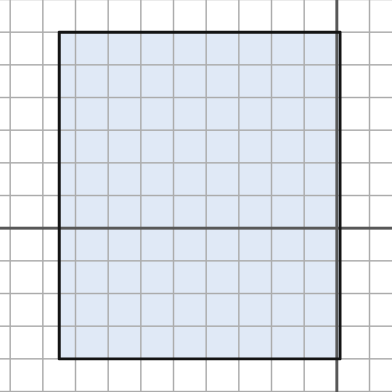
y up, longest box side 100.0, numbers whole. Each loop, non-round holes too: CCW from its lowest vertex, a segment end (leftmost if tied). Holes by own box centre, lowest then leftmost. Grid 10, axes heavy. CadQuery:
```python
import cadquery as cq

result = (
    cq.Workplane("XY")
    .moveTo(-85.0, -40.0)
    .lineTo(1.0, -40.0)
    .lineTo(1.0, 60.0)
    .lineTo(-85.0, 60.0)
    .close()
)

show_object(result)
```